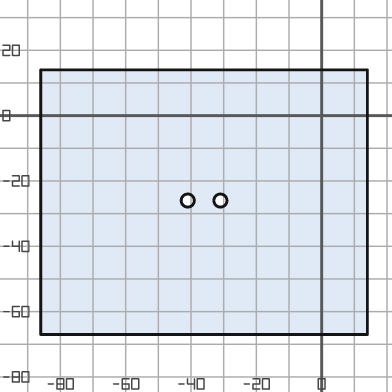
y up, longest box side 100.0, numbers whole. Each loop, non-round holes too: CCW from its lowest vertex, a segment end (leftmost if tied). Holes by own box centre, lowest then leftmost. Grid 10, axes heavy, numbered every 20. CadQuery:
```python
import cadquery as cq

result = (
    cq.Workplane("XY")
    .moveTo(-86.0, -67.0)
    .lineTo(14.0, -67.0)
    .lineTo(14.0, 14.0)
    .lineTo(-86.0, 14.0)
    .close()
    .moveTo(-41.0, -26.0)
    .circle(2.0)
    .moveTo(-31.0, -26.0)
    .circle(2.0)
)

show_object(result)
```